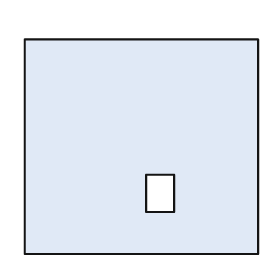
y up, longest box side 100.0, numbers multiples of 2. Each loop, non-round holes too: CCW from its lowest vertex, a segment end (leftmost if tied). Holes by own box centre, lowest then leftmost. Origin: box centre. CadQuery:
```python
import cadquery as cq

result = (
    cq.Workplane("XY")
    .moveTo(-50.0, -46.0)
    .lineTo(50.0, -46.0)
    .lineTo(50.0, 46.0)
    .lineTo(-50.0, 46.0)
    .close()
    .moveTo(2.0, -28.0)
    .lineTo(14.0, -28.0)
    .lineTo(14.0, -12.0)
    .lineTo(2.0, -12.0)
    .close()
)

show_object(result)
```